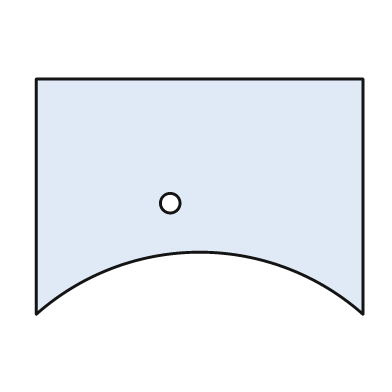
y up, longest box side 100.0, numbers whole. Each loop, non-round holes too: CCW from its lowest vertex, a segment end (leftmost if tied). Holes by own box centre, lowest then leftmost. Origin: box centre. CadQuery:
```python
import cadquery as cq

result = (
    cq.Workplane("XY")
    .moveTo(-50.0, -36.0)
    .threePointArc((0.0, -17.0), (50.0, -36.0))
    .lineTo(50.0, 36.0)
    .lineTo(-50.0, 36.0)
    .close()
    .moveTo(-9.0, -2.0)
    .circle(3.0)
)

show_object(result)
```